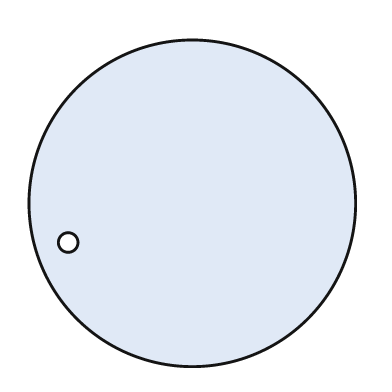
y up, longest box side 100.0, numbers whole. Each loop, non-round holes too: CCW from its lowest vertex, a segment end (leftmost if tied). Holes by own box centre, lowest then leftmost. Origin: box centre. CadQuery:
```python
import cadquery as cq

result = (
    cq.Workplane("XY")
    .moveTo(0.0, 0.0)
    .circle(50.0)
    .moveTo(-38.0, -12.0)
    .circle(3.0)
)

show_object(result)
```